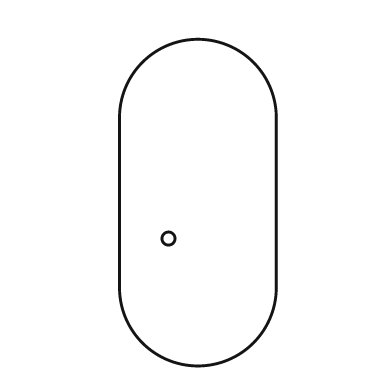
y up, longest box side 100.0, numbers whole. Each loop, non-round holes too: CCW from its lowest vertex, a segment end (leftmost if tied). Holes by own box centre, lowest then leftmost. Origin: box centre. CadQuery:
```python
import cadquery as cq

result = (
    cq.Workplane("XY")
    .moveTo(-24.0, -26.0)
    .threePointArc((0.0, -50.0), (24.0, -26.0))
    .lineTo(24.0, 26.0)
    .threePointArc((0.0, 50.0), (-24.0, 26.0))
    .close()
    .moveTo(-9.0, -11.0)
    .circle(2.0)
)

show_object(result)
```